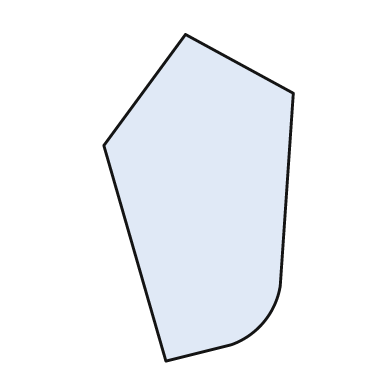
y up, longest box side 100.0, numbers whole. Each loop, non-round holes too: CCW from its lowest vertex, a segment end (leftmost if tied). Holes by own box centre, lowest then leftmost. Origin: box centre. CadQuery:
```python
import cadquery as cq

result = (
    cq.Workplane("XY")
    .moveTo(-10.0, -50.0)
    .lineTo(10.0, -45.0)
    .threePointArc((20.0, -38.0), (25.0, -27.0))
    .lineTo(29.0, 32.0)
    .lineTo(-4.0, 50.0)
    .lineTo(-29.0, 16.0)
    .close()
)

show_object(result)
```